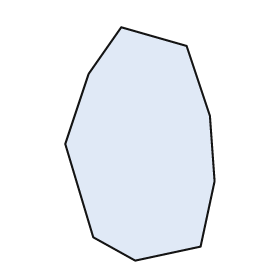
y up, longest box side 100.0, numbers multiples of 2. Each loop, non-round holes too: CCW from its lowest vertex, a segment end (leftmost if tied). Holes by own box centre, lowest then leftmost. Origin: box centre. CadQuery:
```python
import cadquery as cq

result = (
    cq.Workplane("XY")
    .moveTo(-2.0, -50.0)
    .lineTo(26.0, -44.0)
    .lineTo(32.0, -16.0)
    .lineTo(30.0, 12.0)
    .lineTo(20.0, 42.0)
    .lineTo(-8.0, 50.0)
    .lineTo(-22.0, 30.0)
    .lineTo(-32.0, 0.0)
    .lineTo(-20.0, -40.0)
    .close()
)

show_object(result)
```